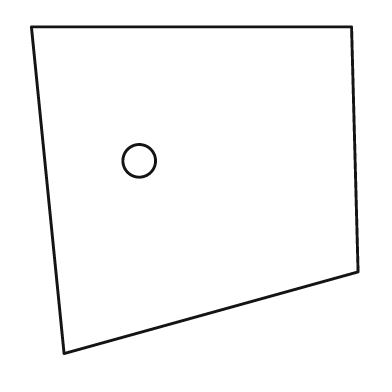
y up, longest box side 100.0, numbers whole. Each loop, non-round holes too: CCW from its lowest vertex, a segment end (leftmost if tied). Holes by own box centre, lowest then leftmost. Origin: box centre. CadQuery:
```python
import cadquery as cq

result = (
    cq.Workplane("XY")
    .moveTo(-40.0, -50.0)
    .lineTo(50.0, -25.0)
    .lineTo(48.0, 50.0)
    .lineTo(-50.0, 50.0)
    .close()
    .moveTo(-17.0, 9.0)
    .circle(5.0)
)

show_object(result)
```